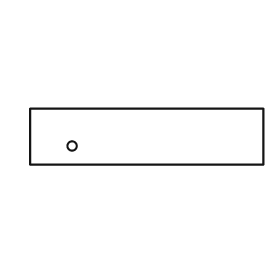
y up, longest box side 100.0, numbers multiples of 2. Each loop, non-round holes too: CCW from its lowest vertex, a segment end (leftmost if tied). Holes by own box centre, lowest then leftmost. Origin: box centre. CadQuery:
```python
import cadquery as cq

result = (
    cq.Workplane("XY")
    .moveTo(-50.0, -12.0)
    .lineTo(50.0, -12.0)
    .lineTo(50.0, 12.0)
    .lineTo(-50.0, 12.0)
    .close()
    .moveTo(-32.0, -4.0)
    .circle(2.0)
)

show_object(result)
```